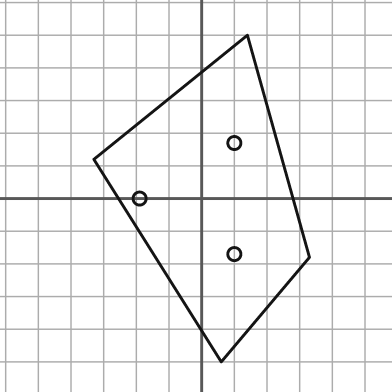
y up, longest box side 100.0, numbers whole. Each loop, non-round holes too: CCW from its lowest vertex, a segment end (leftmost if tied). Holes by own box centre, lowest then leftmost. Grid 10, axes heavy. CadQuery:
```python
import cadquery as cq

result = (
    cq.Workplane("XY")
    .moveTo(6.0, -50.0)
    .lineTo(33.0, -18.0)
    .lineTo(14.0, 50.0)
    .lineTo(-33.0, 12.0)
    .close()
    .moveTo(10.0, -17.0)
    .circle(2.0)
    .moveTo(-19.0, 0.0)
    .circle(2.0)
    .moveTo(10.0, 17.0)
    .circle(2.0)
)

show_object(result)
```